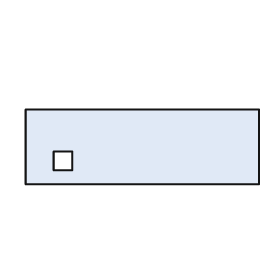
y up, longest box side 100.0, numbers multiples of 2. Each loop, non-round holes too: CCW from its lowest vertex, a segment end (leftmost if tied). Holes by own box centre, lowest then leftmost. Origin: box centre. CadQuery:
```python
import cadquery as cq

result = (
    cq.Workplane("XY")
    .moveTo(-50.0, -16.0)
    .lineTo(50.0, -16.0)
    .lineTo(50.0, 16.0)
    .lineTo(-50.0, 16.0)
    .close()
    .moveTo(-38.0, -10.0)
    .lineTo(-30.0, -10.0)
    .lineTo(-30.0, -2.0)
    .lineTo(-38.0, -2.0)
    .close()
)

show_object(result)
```